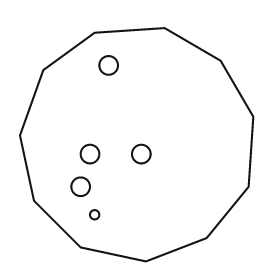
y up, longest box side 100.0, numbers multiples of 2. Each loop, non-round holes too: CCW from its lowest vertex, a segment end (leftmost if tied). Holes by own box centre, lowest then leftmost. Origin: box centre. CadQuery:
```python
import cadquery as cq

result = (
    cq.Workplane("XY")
    .moveTo(4.0, -50.0)
    .lineTo(30.0, -40.0)
    .lineTo(48.0, -18.0)
    .lineTo(50.0, 12.0)
    .lineTo(36.0, 36.0)
    .lineTo(12.0, 50.0)
    .lineTo(-18.0, 48.0)
    .lineTo(-40.0, 32.0)
    .lineTo(-50.0, 4.0)
    .lineTo(-44.0, -24.0)
    .lineTo(-24.0, -44.0)
    .close()
    .moveTo(-18.0, -30.0)
    .circle(2.0)
    .moveTo(-24.0, -18.0)
    .circle(4.0)
    .moveTo(-20.0, -4.0)
    .circle(4.0)
    .moveTo(2.0, -4.0)
    .circle(4.0)
    .moveTo(-12.0, 34.0)
    .circle(4.0)
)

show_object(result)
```